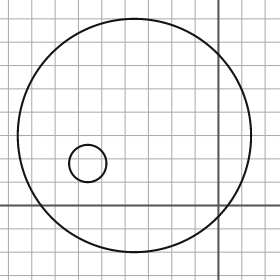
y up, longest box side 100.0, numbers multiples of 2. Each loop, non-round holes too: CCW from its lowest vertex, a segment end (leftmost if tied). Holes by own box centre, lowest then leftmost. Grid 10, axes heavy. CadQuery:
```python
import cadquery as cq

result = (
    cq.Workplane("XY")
    .moveTo(-36.0, 30.0)
    .circle(50.0)
    .moveTo(-56.0, 18.0)
    .circle(8.0)
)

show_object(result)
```